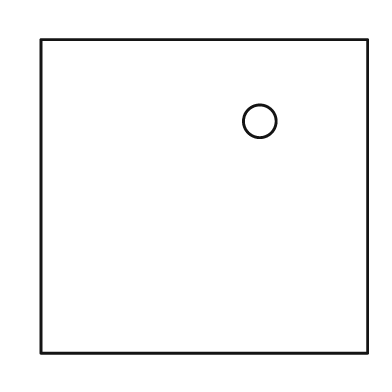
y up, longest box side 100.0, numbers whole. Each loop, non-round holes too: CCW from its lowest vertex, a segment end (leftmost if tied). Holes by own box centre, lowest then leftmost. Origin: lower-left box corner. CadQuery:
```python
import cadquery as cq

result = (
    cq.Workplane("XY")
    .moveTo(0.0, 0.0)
    .lineTo(100.0, 0.0)
    .lineTo(100.0, 96.0)
    .lineTo(0.0, 96.0)
    .close()
    .moveTo(67.0, 71.0)
    .circle(5.0)
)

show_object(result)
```